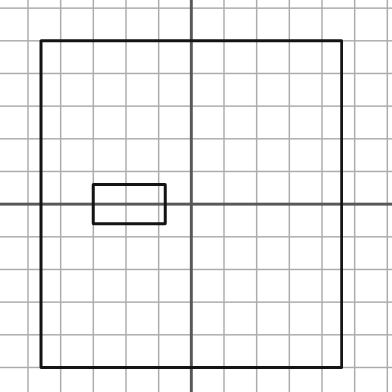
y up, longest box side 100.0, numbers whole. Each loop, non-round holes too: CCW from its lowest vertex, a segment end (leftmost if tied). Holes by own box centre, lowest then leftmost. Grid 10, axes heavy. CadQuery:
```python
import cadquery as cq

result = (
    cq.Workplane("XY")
    .moveTo(-46.0, -50.0)
    .lineTo(46.0, -50.0)
    .lineTo(46.0, 50.0)
    .lineTo(-46.0, 50.0)
    .close()
    .moveTo(-30.0, -6.0)
    .lineTo(-8.0, -6.0)
    .lineTo(-8.0, 6.0)
    .lineTo(-30.0, 6.0)
    .close()
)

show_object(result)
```